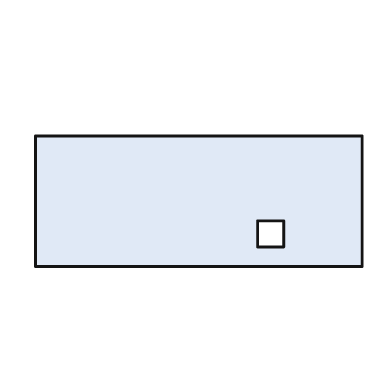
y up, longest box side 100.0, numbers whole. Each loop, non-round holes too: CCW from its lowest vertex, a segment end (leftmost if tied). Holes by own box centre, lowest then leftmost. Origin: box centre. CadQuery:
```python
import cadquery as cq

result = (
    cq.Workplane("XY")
    .moveTo(-50.0, -20.0)
    .lineTo(50.0, -20.0)
    .lineTo(50.0, 20.0)
    .lineTo(-50.0, 20.0)
    .close()
    .moveTo(18.0, -14.0)
    .lineTo(26.0, -14.0)
    .lineTo(26.0, -6.0)
    .lineTo(18.0, -6.0)
    .close()
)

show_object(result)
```